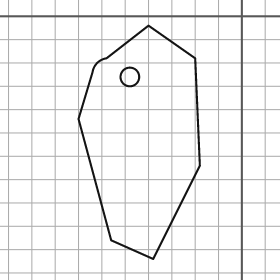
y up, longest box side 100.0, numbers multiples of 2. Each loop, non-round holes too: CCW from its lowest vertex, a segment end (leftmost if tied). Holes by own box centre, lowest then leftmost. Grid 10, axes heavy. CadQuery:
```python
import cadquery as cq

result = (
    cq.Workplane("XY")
    .moveTo(-38.0, -104.0)
    .lineTo(-18.0, -64.0)
    .lineTo(-20.0, -18.0)
    .lineTo(-40.0, -4.0)
    .lineTo(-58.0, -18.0)
    .threePointArc((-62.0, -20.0), (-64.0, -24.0))
    .lineTo(-70.0, -44.0)
    .lineTo(-56.0, -96.0)
    .close()
    .moveTo(-48.0, -26.0)
    .circle(4.0)
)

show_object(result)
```